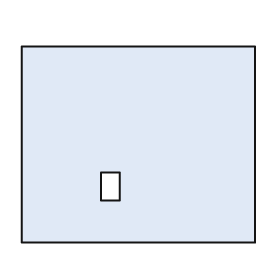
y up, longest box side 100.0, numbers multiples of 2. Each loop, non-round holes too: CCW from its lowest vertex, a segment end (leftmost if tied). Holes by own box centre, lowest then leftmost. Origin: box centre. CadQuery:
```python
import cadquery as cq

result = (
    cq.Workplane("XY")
    .moveTo(-50.0, -42.0)
    .lineTo(50.0, -42.0)
    .lineTo(50.0, 42.0)
    .lineTo(-50.0, 42.0)
    .close()
    .moveTo(-16.0, -24.0)
    .lineTo(-8.0, -24.0)
    .lineTo(-8.0, -12.0)
    .lineTo(-16.0, -12.0)
    .close()
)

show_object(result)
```